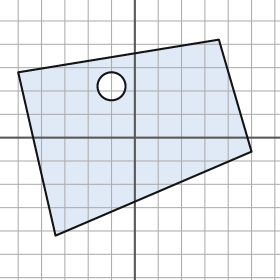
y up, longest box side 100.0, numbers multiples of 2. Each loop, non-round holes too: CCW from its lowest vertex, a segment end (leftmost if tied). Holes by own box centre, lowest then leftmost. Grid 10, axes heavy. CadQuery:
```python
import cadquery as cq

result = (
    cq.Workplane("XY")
    .moveTo(-34.0, -42.0)
    .lineTo(50.0, -6.0)
    .lineTo(36.0, 42.0)
    .lineTo(-50.0, 28.0)
    .close()
    .moveTo(-10.0, 22.0)
    .circle(6.0)
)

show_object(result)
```